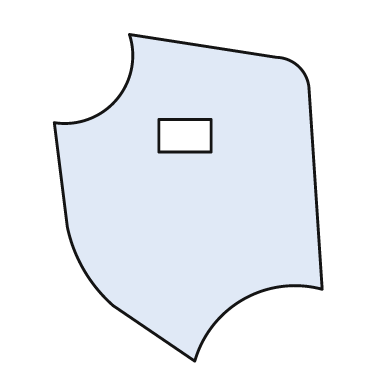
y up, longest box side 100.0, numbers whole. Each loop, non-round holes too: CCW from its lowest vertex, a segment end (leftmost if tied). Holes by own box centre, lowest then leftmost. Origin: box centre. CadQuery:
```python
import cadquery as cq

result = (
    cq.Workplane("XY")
    .moveTo(2.0, -50.0)
    .threePointArc((17.0, -31.0), (41.0, -28.0))
    .lineTo(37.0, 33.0)
    .threePointArc((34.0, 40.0), (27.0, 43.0))
    .lineTo(-18.0, 50.0)
    .threePointArc((-22.0, 30.0), (-41.0, 23.0))
    .lineTo(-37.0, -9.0)
    .threePointArc((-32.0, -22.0), (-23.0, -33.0))
    .close()
    .moveTo(-9.0, 14.0)
    .lineTo(7.0, 14.0)
    .lineTo(7.0, 24.0)
    .lineTo(-9.0, 24.0)
    .close()
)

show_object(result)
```